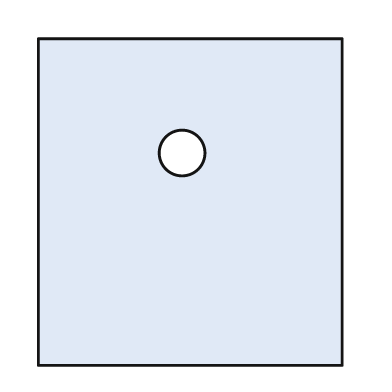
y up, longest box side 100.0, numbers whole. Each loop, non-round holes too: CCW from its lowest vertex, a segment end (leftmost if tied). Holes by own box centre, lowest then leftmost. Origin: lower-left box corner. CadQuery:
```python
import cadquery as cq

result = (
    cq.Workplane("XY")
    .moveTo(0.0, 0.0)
    .lineTo(93.0, 0.0)
    .lineTo(93.0, 100.0)
    .lineTo(0.0, 100.0)
    .close()
    .moveTo(44.0, 65.0)
    .circle(7.0)
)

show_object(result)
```